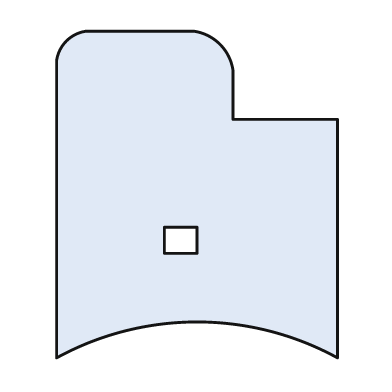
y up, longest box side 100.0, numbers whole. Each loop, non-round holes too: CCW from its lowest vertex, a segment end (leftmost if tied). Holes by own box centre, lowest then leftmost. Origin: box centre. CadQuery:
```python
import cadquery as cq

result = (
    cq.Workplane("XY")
    .moveTo(-43.0, -50.0)
    .threePointArc((0.0, -39.0), (43.0, -50.0))
    .lineTo(43.0, 23.0)
    .lineTo(11.0, 23.0)
    .lineTo(11.0, 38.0)
    .threePointArc((7.0, 46.0), (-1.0, 50.0))
    .lineTo(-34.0, 50.0)
    .threePointArc((-40.0, 47.0), (-43.0, 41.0))
    .close()
    .moveTo(-10.0, -18.0)
    .lineTo(0.0, -18.0)
    .lineTo(0.0, -10.0)
    .lineTo(-10.0, -10.0)
    .close()
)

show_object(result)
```